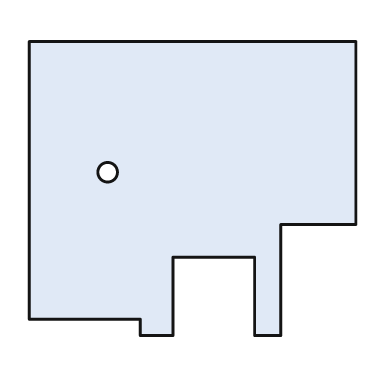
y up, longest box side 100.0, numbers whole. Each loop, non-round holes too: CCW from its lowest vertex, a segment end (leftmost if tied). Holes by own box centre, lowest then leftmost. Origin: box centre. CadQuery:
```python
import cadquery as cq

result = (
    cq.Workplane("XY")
    .moveTo(-16.0, -45.0)
    .lineTo(-6.0, -45.0)
    .lineTo(-6.0, -21.0)
    .lineTo(19.0, -21.0)
    .lineTo(19.0, -45.0)
    .lineTo(27.0, -45.0)
    .lineTo(27.0, -11.0)
    .lineTo(50.0, -11.0)
    .lineTo(50.0, 45.0)
    .lineTo(-50.0, 45.0)
    .lineTo(-50.0, -40.0)
    .lineTo(-16.0, -40.0)
    .close()
    .moveTo(-26.0, 5.0)
    .circle(3.0)
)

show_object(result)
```